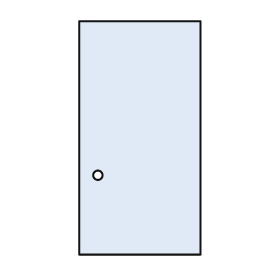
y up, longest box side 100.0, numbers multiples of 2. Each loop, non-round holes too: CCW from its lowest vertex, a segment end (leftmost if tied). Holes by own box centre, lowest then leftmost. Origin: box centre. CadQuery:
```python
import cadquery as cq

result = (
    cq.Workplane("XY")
    .moveTo(-26.0, -50.0)
    .lineTo(26.0, -50.0)
    .lineTo(26.0, 50.0)
    .lineTo(-26.0, 50.0)
    .close()
    .moveTo(-18.0, -16.0)
    .circle(2.0)
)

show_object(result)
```